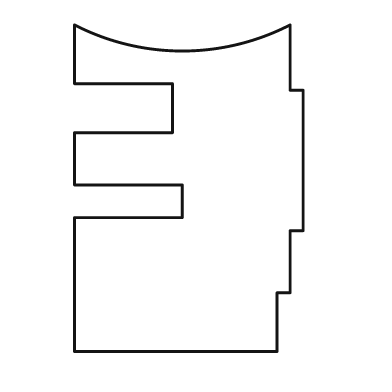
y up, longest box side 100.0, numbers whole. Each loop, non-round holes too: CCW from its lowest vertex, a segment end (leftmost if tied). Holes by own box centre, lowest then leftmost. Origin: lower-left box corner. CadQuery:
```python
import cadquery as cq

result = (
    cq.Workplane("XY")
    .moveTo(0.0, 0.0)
    .lineTo(62.0, 0.0)
    .lineTo(62.0, 18.0)
    .lineTo(66.0, 18.0)
    .lineTo(66.0, 37.0)
    .lineTo(70.0, 37.0)
    .lineTo(70.0, 80.0)
    .lineTo(66.0, 80.0)
    .lineTo(66.0, 100.0)
    .threePointArc((33.0, 92.0), (0.0, 100.0))
    .lineTo(0.0, 82.0)
    .lineTo(30.0, 82.0)
    .lineTo(30.0, 67.0)
    .lineTo(0.0, 67.0)
    .lineTo(0.0, 51.0)
    .lineTo(33.0, 51.0)
    .lineTo(33.0, 41.0)
    .lineTo(0.0, 41.0)
    .close()
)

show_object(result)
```